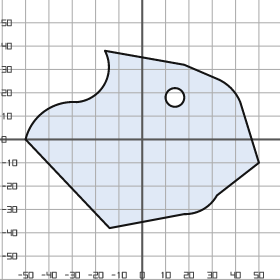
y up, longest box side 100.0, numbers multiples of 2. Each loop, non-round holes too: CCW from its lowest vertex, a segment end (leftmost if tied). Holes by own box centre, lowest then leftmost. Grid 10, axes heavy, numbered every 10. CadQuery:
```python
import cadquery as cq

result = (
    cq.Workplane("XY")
    .moveTo(-14.0, -38.0)
    .lineTo(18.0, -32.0)
    .threePointArc((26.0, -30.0), (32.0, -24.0))
    .lineTo(50.0, -10.0)
    .lineTo(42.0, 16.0)
    .threePointArc((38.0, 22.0), (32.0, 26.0))
    .lineTo(18.0, 32.0)
    .lineTo(-16.0, 38.0)
    .threePointArc((-16.0, 24.0), (-28.0, 16.0))
    .threePointArc((-42.0, 12.0), (-50.0, 0.0))
    .close()
    .moveTo(14.0, 18.0)
    .circle(4.0)
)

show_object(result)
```